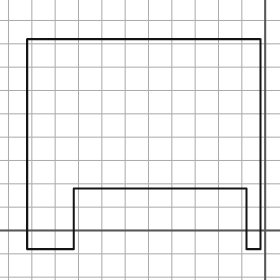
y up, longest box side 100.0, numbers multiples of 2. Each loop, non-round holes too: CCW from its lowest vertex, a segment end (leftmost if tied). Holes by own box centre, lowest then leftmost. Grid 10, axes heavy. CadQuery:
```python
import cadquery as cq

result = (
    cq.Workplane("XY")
    .moveTo(-102.0, -8.0)
    .lineTo(-82.0, -8.0)
    .lineTo(-82.0, 18.0)
    .lineTo(-8.0, 18.0)
    .lineTo(-8.0, -8.0)
    .lineTo(-2.0, -8.0)
    .lineTo(-2.0, 82.0)
    .lineTo(-102.0, 82.0)
    .close()
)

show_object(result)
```